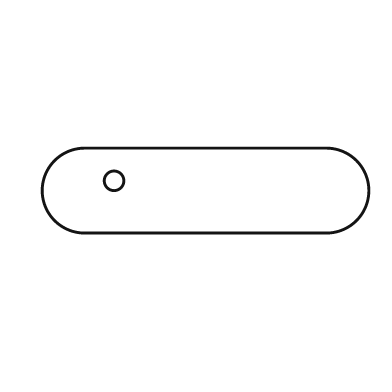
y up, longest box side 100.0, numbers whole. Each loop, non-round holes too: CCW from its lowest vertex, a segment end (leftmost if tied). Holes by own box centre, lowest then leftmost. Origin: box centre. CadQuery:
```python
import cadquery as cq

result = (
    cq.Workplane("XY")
    .moveTo(-37.0, -13.0)
    .lineTo(37.0, -13.0)
    .threePointArc((50.0, 0.0), (37.0, 13.0))
    .lineTo(-37.0, 13.0)
    .threePointArc((-50.0, 0.0), (-37.0, -13.0))
    .close()
    .moveTo(-28.0, 3.0)
    .circle(3.0)
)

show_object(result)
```